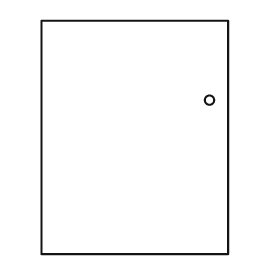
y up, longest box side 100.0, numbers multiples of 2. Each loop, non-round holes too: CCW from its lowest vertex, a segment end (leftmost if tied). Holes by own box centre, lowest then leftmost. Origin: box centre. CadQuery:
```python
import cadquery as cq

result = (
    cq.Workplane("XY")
    .moveTo(-40.0, -50.0)
    .lineTo(40.0, -50.0)
    .lineTo(40.0, 50.0)
    .lineTo(-40.0, 50.0)
    .close()
    .moveTo(32.0, 16.0)
    .circle(2.0)
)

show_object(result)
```